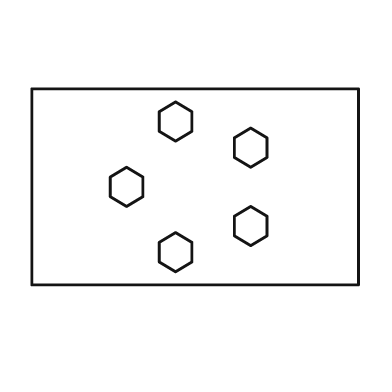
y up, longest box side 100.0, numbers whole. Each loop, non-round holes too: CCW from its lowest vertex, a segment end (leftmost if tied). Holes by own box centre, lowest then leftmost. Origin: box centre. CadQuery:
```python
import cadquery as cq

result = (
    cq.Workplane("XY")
    .moveTo(-50.0, -30.0)
    .lineTo(50.0, -30.0)
    .lineTo(50.0, 30.0)
    .lineTo(-50.0, 30.0)
    .close()
    .moveTo(-6.0, -26.0)
    .lineTo(-1.0, -23.0)
    .lineTo(-1.0, -17.0)
    .lineTo(-6.0, -14.0)
    .lineTo(-11.0, -17.0)
    .lineTo(-11.0, -23.0)
    .close()
    .moveTo(17.0, -18.0)
    .lineTo(22.0, -15.0)
    .lineTo(22.0, -9.0)
    .lineTo(17.0, -6.0)
    .lineTo(12.0, -9.0)
    .lineTo(12.0, -15.0)
    .close()
    .moveTo(-21.0, -6.0)
    .lineTo(-16.0, -3.0)
    .lineTo(-16.0, 3.0)
    .lineTo(-21.0, 6.0)
    .lineTo(-26.0, 3.0)
    .lineTo(-26.0, -3.0)
    .close()
    .moveTo(17.0, 6.0)
    .lineTo(22.0, 9.0)
    .lineTo(22.0, 15.0)
    .lineTo(17.0, 18.0)
    .lineTo(12.0, 15.0)
    .lineTo(12.0, 9.0)
    .close()
    .moveTo(-6.0, 14.0)
    .lineTo(-1.0, 17.0)
    .lineTo(-1.0, 23.0)
    .lineTo(-6.0, 26.0)
    .lineTo(-11.0, 23.0)
    .lineTo(-11.0, 17.0)
    .close()
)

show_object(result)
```